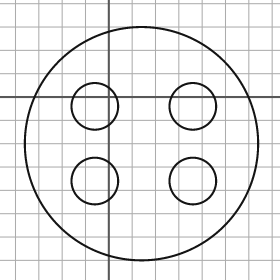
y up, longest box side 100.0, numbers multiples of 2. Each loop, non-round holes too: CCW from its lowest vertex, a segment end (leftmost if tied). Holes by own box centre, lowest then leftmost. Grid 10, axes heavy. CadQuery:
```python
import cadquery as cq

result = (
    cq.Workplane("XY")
    .moveTo(14.0, -20.0)
    .circle(50.0)
    .moveTo(-6.0, -36.0)
    .circle(10.0)
    .moveTo(36.0, -36.0)
    .circle(10.0)
    .moveTo(-6.0, -4.0)
    .circle(10.0)
    .moveTo(36.0, -4.0)
    .circle(10.0)
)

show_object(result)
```